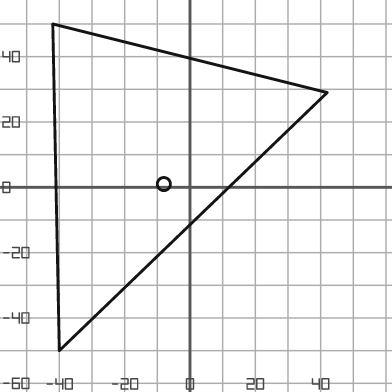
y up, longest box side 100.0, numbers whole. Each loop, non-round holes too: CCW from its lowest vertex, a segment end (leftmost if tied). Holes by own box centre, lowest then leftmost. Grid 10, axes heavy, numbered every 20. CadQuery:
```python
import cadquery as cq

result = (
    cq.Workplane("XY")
    .moveTo(-40.0, -50.0)
    .lineTo(42.0, 29.0)
    .lineTo(-42.0, 50.0)
    .close()
    .moveTo(-8.0, 1.0)
    .circle(2.0)
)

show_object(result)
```